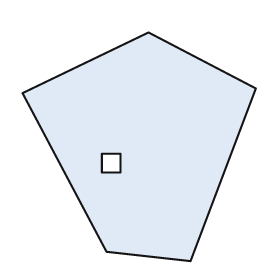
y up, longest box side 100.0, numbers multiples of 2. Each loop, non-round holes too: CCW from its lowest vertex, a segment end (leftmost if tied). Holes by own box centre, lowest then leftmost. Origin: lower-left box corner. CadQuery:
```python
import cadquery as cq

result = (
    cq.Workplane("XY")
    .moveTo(72.0, 0.0)
    .lineTo(100.0, 74.0)
    .lineTo(54.0, 98.0)
    .lineTo(0.0, 72.0)
    .lineTo(36.0, 4.0)
    .close()
    .moveTo(34.0, 38.0)
    .lineTo(42.0, 38.0)
    .lineTo(42.0, 46.0)
    .lineTo(34.0, 46.0)
    .close()
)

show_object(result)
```